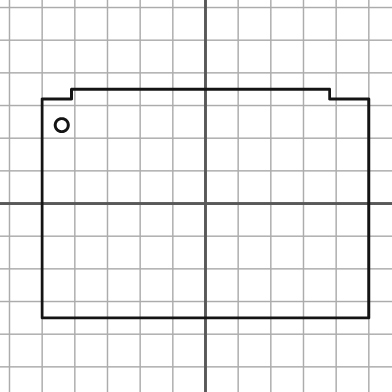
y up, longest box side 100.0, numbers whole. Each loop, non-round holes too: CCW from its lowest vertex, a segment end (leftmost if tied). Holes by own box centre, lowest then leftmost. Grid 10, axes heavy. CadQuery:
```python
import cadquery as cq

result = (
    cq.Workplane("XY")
    .moveTo(-50.0, -35.0)
    .lineTo(50.0, -35.0)
    .lineTo(50.0, 32.0)
    .lineTo(38.0, 32.0)
    .lineTo(38.0, 35.0)
    .lineTo(-41.0, 35.0)
    .lineTo(-41.0, 32.0)
    .lineTo(-50.0, 32.0)
    .close()
    .moveTo(-44.0, 24.0)
    .circle(2.0)
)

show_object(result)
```